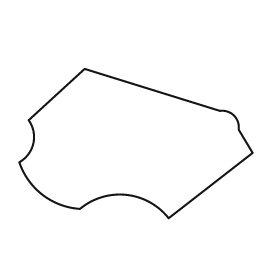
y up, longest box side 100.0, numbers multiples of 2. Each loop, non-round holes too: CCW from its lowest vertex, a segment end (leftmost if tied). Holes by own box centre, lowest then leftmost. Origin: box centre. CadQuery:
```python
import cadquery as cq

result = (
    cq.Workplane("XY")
    .moveTo(14.0, -32.0)
    .lineTo(50.0, -4.0)
    .lineTo(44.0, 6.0)
    .threePointArc((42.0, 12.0), (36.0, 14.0))
    .lineTo(-22.0, 32.0)
    .lineTo(-46.0, 10.0)
    .threePointArc((-44.0, 0.0), (-50.0, -8.0))
    .threePointArc((-40.0, -22.0), (-24.0, -28.0))
    .threePointArc((-4.0, -22.0), (14.0, -32.0))
    .close()
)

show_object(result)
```